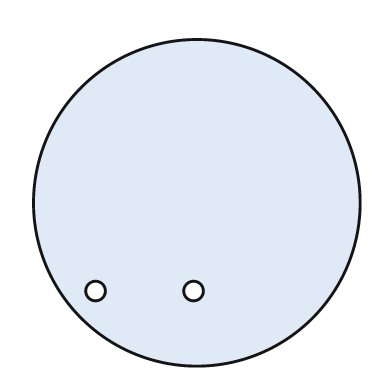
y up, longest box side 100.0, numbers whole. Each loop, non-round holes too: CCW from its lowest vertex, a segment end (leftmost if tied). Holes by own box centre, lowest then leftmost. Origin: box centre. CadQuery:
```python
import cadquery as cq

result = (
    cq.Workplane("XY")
    .moveTo(0.0, 0.0)
    .circle(50.0)
    .moveTo(-31.0, -27.0)
    .circle(3.0)
    .moveTo(-1.0, -27.0)
    .circle(3.0)
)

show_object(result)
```